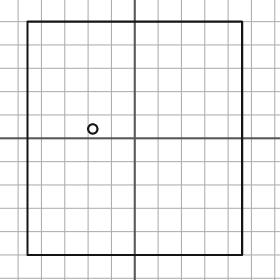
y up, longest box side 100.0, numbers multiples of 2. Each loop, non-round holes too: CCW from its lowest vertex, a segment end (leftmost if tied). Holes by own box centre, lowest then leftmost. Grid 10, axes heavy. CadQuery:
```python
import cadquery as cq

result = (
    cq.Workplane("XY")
    .moveTo(-46.0, -50.0)
    .lineTo(46.0, -50.0)
    .lineTo(46.0, 50.0)
    .lineTo(-46.0, 50.0)
    .close()
    .moveTo(-18.0, 4.0)
    .circle(2.0)
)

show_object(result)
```